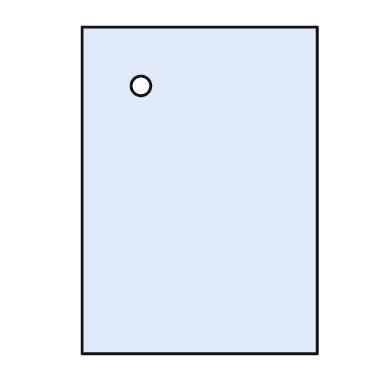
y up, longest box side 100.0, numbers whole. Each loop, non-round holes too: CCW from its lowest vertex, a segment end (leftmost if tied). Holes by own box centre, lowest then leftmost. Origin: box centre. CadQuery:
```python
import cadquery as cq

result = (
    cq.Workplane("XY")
    .moveTo(-36.0, -50.0)
    .lineTo(36.0, -50.0)
    .lineTo(36.0, 50.0)
    .lineTo(-36.0, 50.0)
    .close()
    .moveTo(-18.0, 32.0)
    .circle(3.0)
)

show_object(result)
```